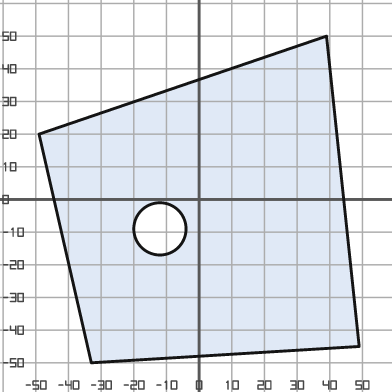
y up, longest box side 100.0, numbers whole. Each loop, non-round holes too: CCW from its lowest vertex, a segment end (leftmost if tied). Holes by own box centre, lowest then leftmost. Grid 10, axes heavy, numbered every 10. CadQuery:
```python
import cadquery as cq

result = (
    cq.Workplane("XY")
    .moveTo(-33.0, -50.0)
    .lineTo(49.0, -45.0)
    .lineTo(39.0, 50.0)
    .lineTo(-49.0, 20.0)
    .close()
    .moveTo(-12.0, -9.0)
    .circle(8.0)
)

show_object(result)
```